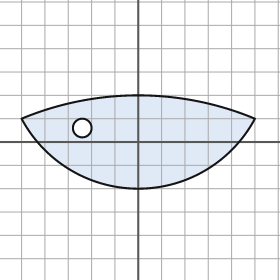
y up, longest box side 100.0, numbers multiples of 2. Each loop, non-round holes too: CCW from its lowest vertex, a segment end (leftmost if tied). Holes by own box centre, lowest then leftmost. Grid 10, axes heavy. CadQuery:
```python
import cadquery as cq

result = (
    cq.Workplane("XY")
    .moveTo(-50.0, 10.0)
    .threePointArc((0.0, -20.0), (50.0, 10.0))
    .threePointArc((0.0, 20.0), (-50.0, 10.0))
    .close()
    .moveTo(-24.0, 6.0)
    .circle(4.0)
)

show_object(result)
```